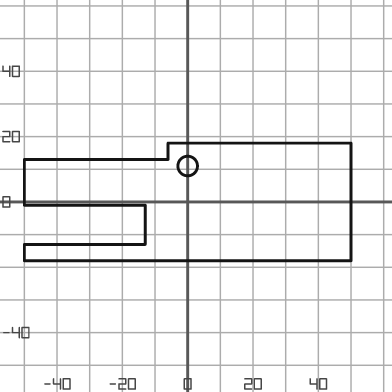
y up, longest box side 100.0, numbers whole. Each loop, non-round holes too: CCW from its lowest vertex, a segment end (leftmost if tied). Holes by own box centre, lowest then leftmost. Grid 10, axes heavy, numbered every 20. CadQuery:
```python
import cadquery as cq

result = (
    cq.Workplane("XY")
    .moveTo(-50.0, -18.0)
    .lineTo(50.0, -18.0)
    .lineTo(50.0, 18.0)
    .lineTo(-6.0, 18.0)
    .lineTo(-6.0, 13.0)
    .lineTo(-50.0, 13.0)
    .lineTo(-50.0, -1.0)
    .lineTo(-13.0, -1.0)
    .lineTo(-13.0, -13.0)
    .lineTo(-50.0, -13.0)
    .close()
    .moveTo(0.0, 11.0)
    .circle(3.0)
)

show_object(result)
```